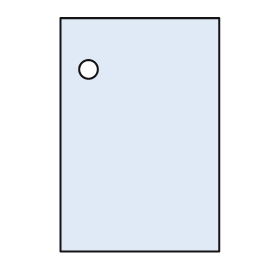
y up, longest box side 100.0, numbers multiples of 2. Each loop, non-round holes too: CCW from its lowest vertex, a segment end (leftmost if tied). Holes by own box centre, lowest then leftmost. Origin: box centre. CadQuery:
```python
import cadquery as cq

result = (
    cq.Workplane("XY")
    .moveTo(-34.0, -50.0)
    .lineTo(34.0, -50.0)
    .lineTo(34.0, 50.0)
    .lineTo(-34.0, 50.0)
    .close()
    .moveTo(-22.0, 28.0)
    .circle(4.0)
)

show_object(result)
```